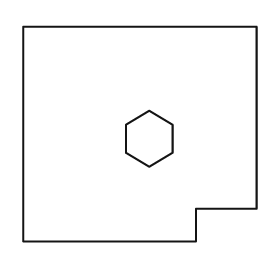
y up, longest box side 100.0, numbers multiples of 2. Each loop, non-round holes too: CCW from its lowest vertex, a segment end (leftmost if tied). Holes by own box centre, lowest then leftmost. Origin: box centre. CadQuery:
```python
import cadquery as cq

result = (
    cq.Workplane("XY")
    .moveTo(-50.0, -46.0)
    .lineTo(24.0, -46.0)
    .lineTo(24.0, -32.0)
    .lineTo(50.0, -32.0)
    .lineTo(50.0, 46.0)
    .lineTo(-50.0, 46.0)
    .close()
    .moveTo(4.0, -14.0)
    .lineTo(14.0, -8.0)
    .lineTo(14.0, 4.0)
    .lineTo(4.0, 10.0)
    .lineTo(-6.0, 4.0)
    .lineTo(-6.0, -8.0)
    .close()
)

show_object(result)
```